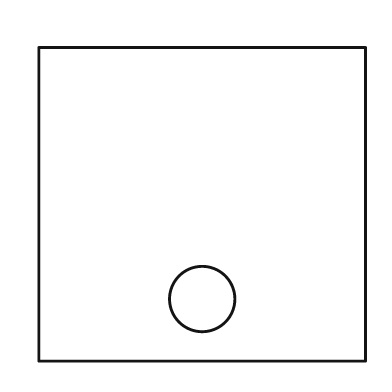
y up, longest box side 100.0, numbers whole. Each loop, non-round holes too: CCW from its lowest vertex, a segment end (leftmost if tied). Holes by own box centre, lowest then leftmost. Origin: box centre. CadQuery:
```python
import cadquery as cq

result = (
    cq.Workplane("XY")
    .moveTo(-50.0, -48.0)
    .lineTo(50.0, -48.0)
    .lineTo(50.0, 48.0)
    .lineTo(-50.0, 48.0)
    .close()
    .moveTo(0.0, -29.0)
    .circle(10.0)
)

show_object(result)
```